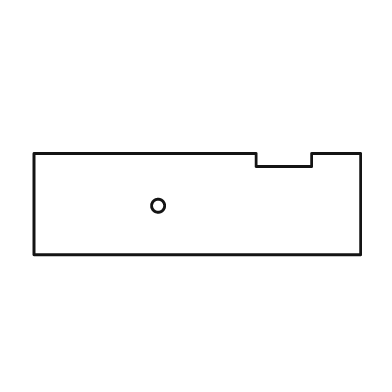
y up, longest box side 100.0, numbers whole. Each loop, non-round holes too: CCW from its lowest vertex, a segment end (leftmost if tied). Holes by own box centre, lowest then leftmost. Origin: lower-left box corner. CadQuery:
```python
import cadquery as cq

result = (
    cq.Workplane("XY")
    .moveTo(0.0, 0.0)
    .lineTo(100.0, 0.0)
    .lineTo(100.0, 31.0)
    .lineTo(85.0, 31.0)
    .lineTo(85.0, 27.0)
    .lineTo(68.0, 27.0)
    .lineTo(68.0, 31.0)
    .lineTo(0.0, 31.0)
    .close()
    .moveTo(38.0, 15.0)
    .circle(2.0)
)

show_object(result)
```